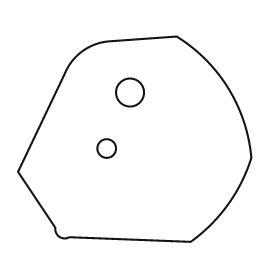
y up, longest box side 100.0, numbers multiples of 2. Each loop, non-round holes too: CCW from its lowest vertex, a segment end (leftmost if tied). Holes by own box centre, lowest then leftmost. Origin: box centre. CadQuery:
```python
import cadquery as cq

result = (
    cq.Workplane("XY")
    .moveTo(24.0, -44.0)
    .threePointArc((40.0, -28.0), (50.0, -8.0))
    .threePointArc((40.0, 22.0), (18.0, 44.0))
    .lineTo(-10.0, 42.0)
    .threePointArc((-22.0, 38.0), (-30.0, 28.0))
    .lineTo(-50.0, -14.0)
    .lineTo(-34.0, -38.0)
    .threePointArc((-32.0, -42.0), (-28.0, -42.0))
    .close()
    .moveTo(-12.0, -4.0)
    .circle(4.0)
    .moveTo(-2.0, 20.0)
    .circle(6.0)
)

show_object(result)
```